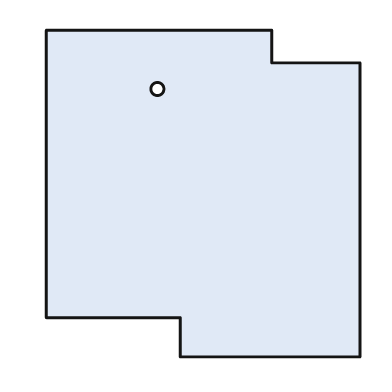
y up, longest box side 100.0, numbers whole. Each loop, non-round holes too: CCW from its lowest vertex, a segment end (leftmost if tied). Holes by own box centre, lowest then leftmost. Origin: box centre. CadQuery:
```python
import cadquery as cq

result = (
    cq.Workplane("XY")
    .moveTo(-7.0, -50.0)
    .lineTo(48.0, -50.0)
    .lineTo(48.0, 40.0)
    .lineTo(21.0, 40.0)
    .lineTo(21.0, 50.0)
    .lineTo(-48.0, 50.0)
    .lineTo(-48.0, -38.0)
    .lineTo(-7.0, -38.0)
    .close()
    .moveTo(-14.0, 32.0)
    .circle(2.0)
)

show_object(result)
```